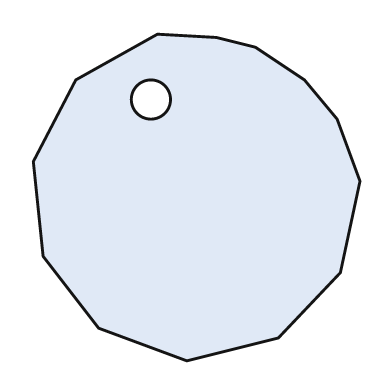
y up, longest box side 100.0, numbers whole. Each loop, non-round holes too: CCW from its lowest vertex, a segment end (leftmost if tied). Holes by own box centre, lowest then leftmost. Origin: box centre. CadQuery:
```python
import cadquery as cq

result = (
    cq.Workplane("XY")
    .moveTo(-3.0, -50.0)
    .lineTo(25.0, -43.0)
    .lineTo(44.0, -23.0)
    .lineTo(50.0, 5.0)
    .lineTo(43.0, 24.0)
    .lineTo(33.0, 36.0)
    .lineTo(18.0, 46.0)
    .lineTo(6.0, 49.0)
    .lineTo(-12.0, 50.0)
    .lineTo(-37.0, 36.0)
    .lineTo(-50.0, 11.0)
    .lineTo(-47.0, -18.0)
    .lineTo(-30.0, -40.0)
    .close()
    .moveTo(-14.0, 30.0)
    .circle(6.0)
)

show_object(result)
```